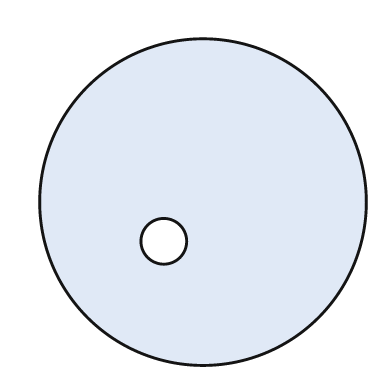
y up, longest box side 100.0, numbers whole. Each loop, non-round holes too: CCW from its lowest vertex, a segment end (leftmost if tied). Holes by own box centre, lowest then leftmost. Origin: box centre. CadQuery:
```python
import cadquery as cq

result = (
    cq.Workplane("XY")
    .moveTo(0.0, 0.0)
    .circle(50.0)
    .moveTo(-12.0, -12.0)
    .circle(7.0)
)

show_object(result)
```